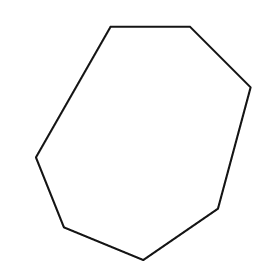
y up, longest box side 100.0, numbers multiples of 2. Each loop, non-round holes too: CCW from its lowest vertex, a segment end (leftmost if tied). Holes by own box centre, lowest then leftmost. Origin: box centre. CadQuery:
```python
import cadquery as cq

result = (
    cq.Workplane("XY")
    .moveTo(0.0, -50.0)
    .lineTo(32.0, -28.0)
    .lineTo(46.0, 24.0)
    .lineTo(20.0, 50.0)
    .lineTo(-14.0, 50.0)
    .lineTo(-46.0, -6.0)
    .lineTo(-34.0, -36.0)
    .close()
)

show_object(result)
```